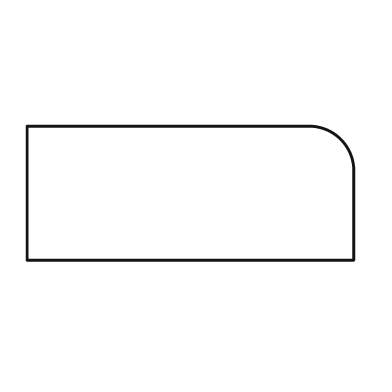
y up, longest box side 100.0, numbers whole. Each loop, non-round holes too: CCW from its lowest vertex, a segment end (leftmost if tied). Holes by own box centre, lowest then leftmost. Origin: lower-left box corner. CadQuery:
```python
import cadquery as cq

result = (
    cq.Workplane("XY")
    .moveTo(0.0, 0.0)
    .lineTo(100.0, 0.0)
    .lineTo(100.0, 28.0)
    .threePointArc((96.0, 37.0), (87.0, 41.0))
    .lineTo(0.0, 41.0)
    .close()
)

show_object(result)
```